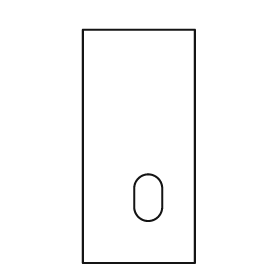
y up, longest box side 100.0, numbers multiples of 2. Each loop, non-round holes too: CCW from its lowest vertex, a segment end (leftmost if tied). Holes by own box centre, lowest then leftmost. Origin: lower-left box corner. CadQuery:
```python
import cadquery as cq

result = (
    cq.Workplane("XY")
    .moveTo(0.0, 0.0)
    .lineTo(48.0, 0.0)
    .lineTo(48.0, 100.0)
    .lineTo(0.0, 100.0)
    .close()
    .moveTo(22.0, 24.0)
    .threePointArc((28.0, 18.0), (34.0, 24.0))
    .lineTo(34.0, 32.0)
    .threePointArc((28.0, 38.0), (22.0, 32.0))
    .close()
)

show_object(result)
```